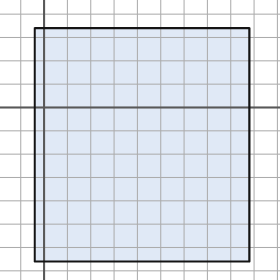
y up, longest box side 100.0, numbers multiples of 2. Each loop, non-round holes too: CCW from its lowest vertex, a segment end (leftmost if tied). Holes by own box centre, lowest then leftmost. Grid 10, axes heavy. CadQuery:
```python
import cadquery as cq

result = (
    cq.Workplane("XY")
    .moveTo(-4.0, -66.0)
    .lineTo(88.0, -66.0)
    .lineTo(88.0, 34.0)
    .lineTo(-4.0, 34.0)
    .close()
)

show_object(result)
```